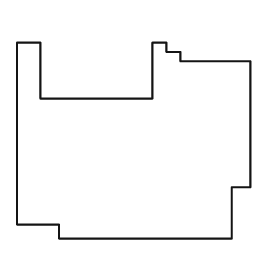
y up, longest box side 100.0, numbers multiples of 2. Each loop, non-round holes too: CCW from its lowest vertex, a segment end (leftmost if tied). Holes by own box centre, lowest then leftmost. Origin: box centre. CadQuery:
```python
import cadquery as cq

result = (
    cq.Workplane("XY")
    .moveTo(-32.0, -42.0)
    .lineTo(42.0, -42.0)
    .lineTo(42.0, -20.0)
    .lineTo(50.0, -20.0)
    .lineTo(50.0, 34.0)
    .lineTo(20.0, 34.0)
    .lineTo(20.0, 38.0)
    .lineTo(14.0, 38.0)
    .lineTo(14.0, 42.0)
    .lineTo(8.0, 42.0)
    .lineTo(8.0, 18.0)
    .lineTo(-40.0, 18.0)
    .lineTo(-40.0, 42.0)
    .lineTo(-50.0, 42.0)
    .lineTo(-50.0, -36.0)
    .lineTo(-32.0, -36.0)
    .close()
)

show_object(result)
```